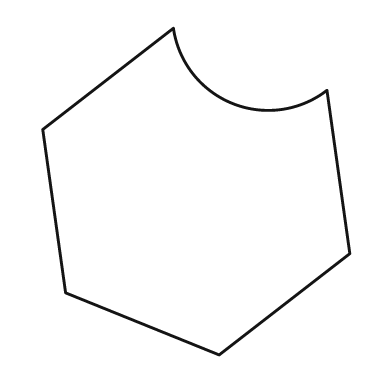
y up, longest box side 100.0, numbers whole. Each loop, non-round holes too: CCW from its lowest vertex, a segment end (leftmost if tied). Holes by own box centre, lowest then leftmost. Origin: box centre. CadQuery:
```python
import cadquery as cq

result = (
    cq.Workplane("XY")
    .moveTo(7.0, -50.0)
    .lineTo(47.0, -19.0)
    .lineTo(40.0, 31.0)
    .threePointArc((11.0, 27.0), (-7.0, 50.0))
    .lineTo(-47.0, 19.0)
    .lineTo(-40.0, -31.0)
    .close()
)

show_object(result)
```